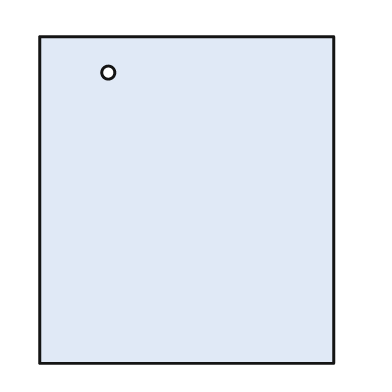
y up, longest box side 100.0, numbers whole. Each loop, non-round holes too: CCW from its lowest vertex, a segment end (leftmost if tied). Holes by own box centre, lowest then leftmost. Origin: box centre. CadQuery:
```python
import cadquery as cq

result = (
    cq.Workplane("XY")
    .moveTo(-45.0, -50.0)
    .lineTo(45.0, -50.0)
    .lineTo(45.0, 50.0)
    .lineTo(-45.0, 50.0)
    .close()
    .moveTo(-24.0, 39.0)
    .circle(2.0)
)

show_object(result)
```